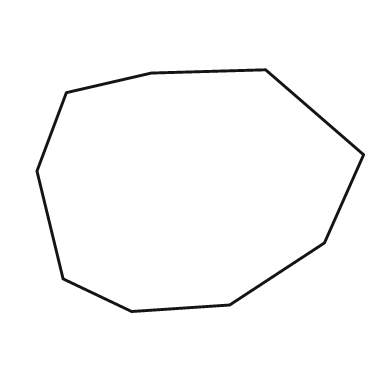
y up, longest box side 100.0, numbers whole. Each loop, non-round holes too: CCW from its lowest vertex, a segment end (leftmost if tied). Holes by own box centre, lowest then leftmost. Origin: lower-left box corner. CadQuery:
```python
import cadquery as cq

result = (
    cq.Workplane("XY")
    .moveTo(29.0, 0.0)
    .lineTo(59.0, 2.0)
    .lineTo(88.0, 21.0)
    .lineTo(100.0, 48.0)
    .lineTo(70.0, 74.0)
    .lineTo(35.0, 73.0)
    .lineTo(9.0, 67.0)
    .lineTo(0.0, 43.0)
    .lineTo(8.0, 10.0)
    .close()
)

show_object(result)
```